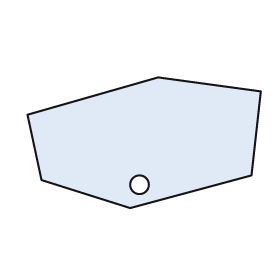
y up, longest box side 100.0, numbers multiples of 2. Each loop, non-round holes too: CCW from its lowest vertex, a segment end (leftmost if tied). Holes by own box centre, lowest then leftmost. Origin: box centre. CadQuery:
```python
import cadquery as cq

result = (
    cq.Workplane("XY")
    .moveTo(-6.0, -28.0)
    .lineTo(46.0, -14.0)
    .lineTo(50.0, 22.0)
    .lineTo(6.0, 28.0)
    .lineTo(-50.0, 12.0)
    .lineTo(-44.0, -16.0)
    .close()
    .moveTo(-2.0, -18.0)
    .circle(4.0)
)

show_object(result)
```